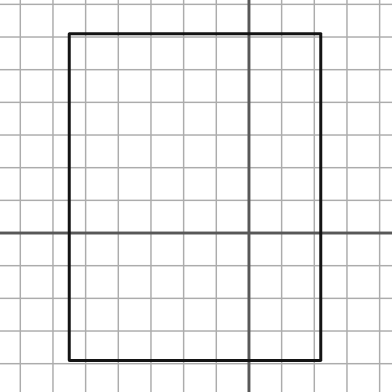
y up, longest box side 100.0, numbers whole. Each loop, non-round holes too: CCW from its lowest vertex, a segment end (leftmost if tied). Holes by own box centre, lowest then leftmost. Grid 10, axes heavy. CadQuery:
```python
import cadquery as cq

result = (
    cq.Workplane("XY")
    .moveTo(-55.0, -39.0)
    .lineTo(22.0, -39.0)
    .lineTo(22.0, 61.0)
    .lineTo(-55.0, 61.0)
    .close()
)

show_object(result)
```